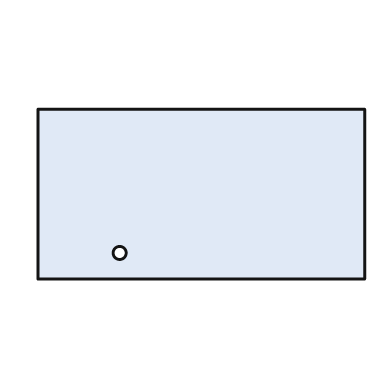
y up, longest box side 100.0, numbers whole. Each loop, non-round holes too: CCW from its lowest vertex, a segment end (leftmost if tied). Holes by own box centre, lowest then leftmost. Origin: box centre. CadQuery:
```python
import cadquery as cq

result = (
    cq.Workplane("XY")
    .moveTo(-50.0, -26.0)
    .lineTo(50.0, -26.0)
    .lineTo(50.0, 26.0)
    .lineTo(-50.0, 26.0)
    .close()
    .moveTo(-25.0, -18.0)
    .circle(2.0)
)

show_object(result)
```